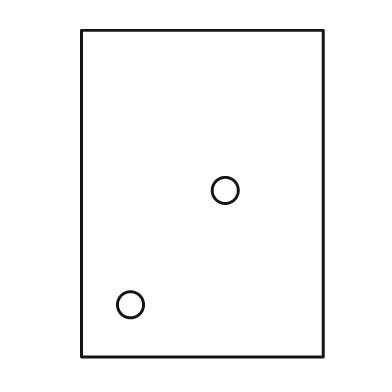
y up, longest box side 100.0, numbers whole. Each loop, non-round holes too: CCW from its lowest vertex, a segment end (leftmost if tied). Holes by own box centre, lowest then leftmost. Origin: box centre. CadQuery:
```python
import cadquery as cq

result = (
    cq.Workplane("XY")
    .moveTo(-37.0, -50.0)
    .lineTo(37.0, -50.0)
    .lineTo(37.0, 50.0)
    .lineTo(-37.0, 50.0)
    .close()
    .moveTo(-22.0, -34.0)
    .circle(4.0)
    .moveTo(7.0, 1.0)
    .circle(4.0)
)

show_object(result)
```